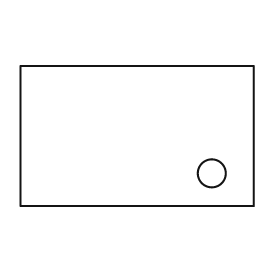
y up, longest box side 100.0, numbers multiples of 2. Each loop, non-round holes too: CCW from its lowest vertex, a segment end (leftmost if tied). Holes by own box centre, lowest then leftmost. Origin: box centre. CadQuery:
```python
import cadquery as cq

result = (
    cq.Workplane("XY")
    .moveTo(-50.0, -30.0)
    .lineTo(50.0, -30.0)
    .lineTo(50.0, 30.0)
    .lineTo(-50.0, 30.0)
    .close()
    .moveTo(32.0, -16.0)
    .circle(6.0)
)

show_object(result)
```